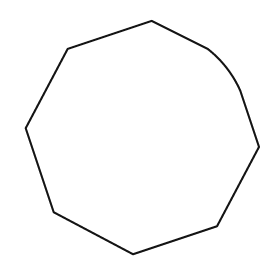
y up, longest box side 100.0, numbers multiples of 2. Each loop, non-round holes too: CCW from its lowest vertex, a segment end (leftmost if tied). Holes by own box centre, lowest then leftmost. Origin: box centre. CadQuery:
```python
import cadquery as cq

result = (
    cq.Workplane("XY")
    .moveTo(-4.0, -50.0)
    .lineTo(32.0, -38.0)
    .lineTo(50.0, -4.0)
    .lineTo(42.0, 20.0)
    .threePointArc((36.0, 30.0), (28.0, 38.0))
    .lineTo(4.0, 50.0)
    .lineTo(-32.0, 38.0)
    .lineTo(-50.0, 4.0)
    .lineTo(-38.0, -32.0)
    .close()
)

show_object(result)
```